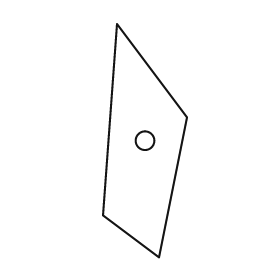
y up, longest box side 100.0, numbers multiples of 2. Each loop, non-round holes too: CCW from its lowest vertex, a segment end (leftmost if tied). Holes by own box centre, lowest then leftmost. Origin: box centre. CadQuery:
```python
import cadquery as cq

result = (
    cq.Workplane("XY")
    .moveTo(6.0, -50.0)
    .lineTo(18.0, 10.0)
    .lineTo(-12.0, 50.0)
    .lineTo(-18.0, -32.0)
    .close()
    .moveTo(0.0, 0.0)
    .circle(4.0)
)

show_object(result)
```